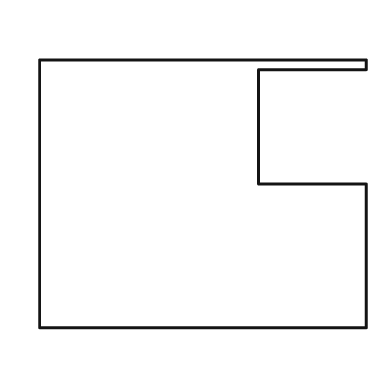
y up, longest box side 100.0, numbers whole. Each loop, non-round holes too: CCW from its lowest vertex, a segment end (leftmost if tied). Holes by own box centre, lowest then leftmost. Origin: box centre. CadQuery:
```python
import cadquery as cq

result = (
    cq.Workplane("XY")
    .moveTo(-50.0, -41.0)
    .lineTo(50.0, -41.0)
    .lineTo(50.0, 3.0)
    .lineTo(17.0, 3.0)
    .lineTo(17.0, 38.0)
    .lineTo(50.0, 38.0)
    .lineTo(50.0, 41.0)
    .lineTo(-50.0, 41.0)
    .close()
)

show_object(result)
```